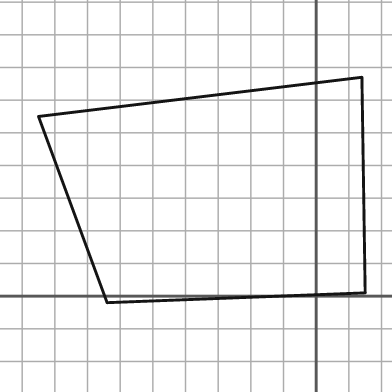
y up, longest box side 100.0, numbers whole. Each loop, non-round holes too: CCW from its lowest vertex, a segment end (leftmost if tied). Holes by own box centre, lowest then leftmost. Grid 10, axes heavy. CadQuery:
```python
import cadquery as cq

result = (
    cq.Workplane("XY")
    .moveTo(-64.0, -2.0)
    .lineTo(15.0, 1.0)
    .lineTo(14.0, 67.0)
    .lineTo(-85.0, 55.0)
    .close()
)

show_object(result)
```